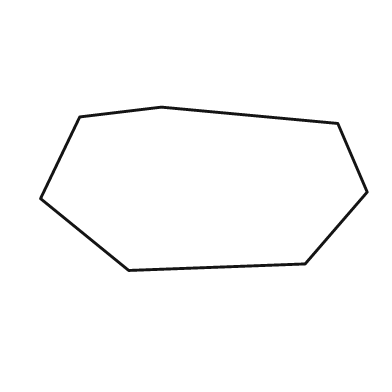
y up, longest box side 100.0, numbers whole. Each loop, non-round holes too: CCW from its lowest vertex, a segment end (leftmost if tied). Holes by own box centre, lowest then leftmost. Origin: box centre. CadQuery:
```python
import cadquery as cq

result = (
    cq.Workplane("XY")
    .moveTo(-23.0, -25.0)
    .lineTo(31.0, -23.0)
    .lineTo(50.0, -1.0)
    .lineTo(41.0, 20.0)
    .lineTo(-13.0, 25.0)
    .lineTo(-38.0, 22.0)
    .lineTo(-50.0, -3.0)
    .close()
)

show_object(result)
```